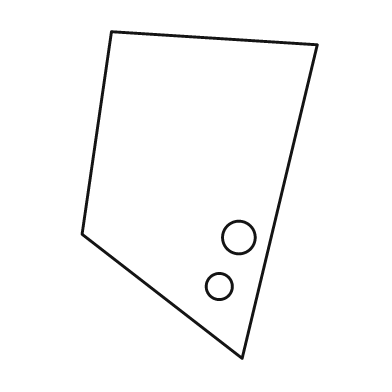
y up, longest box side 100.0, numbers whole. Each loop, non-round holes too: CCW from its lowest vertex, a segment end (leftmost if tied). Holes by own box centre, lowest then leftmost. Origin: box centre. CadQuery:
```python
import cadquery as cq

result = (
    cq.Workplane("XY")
    .moveTo(13.0, -50.0)
    .lineTo(36.0, 46.0)
    .lineTo(-27.0, 50.0)
    .lineTo(-36.0, -12.0)
    .close()
    .moveTo(6.0, -28.0)
    .circle(4.0)
    .moveTo(12.0, -13.0)
    .circle(5.0)
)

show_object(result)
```